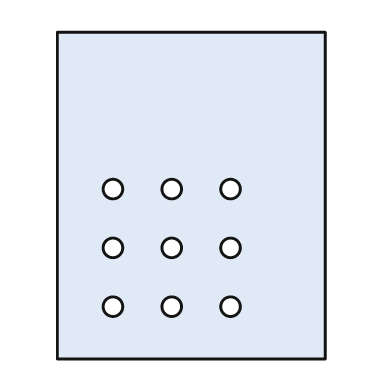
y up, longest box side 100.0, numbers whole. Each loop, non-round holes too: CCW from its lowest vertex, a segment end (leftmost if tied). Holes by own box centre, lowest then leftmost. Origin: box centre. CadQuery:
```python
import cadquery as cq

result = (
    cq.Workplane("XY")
    .moveTo(-41.0, -50.0)
    .lineTo(41.0, -50.0)
    .lineTo(41.0, 50.0)
    .lineTo(-41.0, 50.0)
    .close()
    .moveTo(-24.0, -34.0)
    .circle(3.0)
    .moveTo(-6.0, -34.0)
    .circle(3.0)
    .moveTo(12.0, -34.0)
    .circle(3.0)
    .moveTo(-24.0, -16.0)
    .circle(3.0)
    .moveTo(-6.0, -16.0)
    .circle(3.0)
    .moveTo(12.0, -16.0)
    .circle(3.0)
    .moveTo(-24.0, 2.0)
    .circle(3.0)
    .moveTo(-6.0, 2.0)
    .circle(3.0)
    .moveTo(12.0, 2.0)
    .circle(3.0)
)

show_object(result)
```